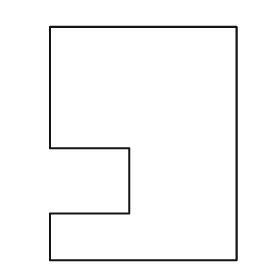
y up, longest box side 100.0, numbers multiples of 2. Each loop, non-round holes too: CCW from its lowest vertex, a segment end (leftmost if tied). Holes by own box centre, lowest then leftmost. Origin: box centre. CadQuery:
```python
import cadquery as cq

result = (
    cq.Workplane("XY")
    .moveTo(-40.0, -50.0)
    .lineTo(40.0, -50.0)
    .lineTo(40.0, 50.0)
    .lineTo(-40.0, 50.0)
    .lineTo(-40.0, -2.0)
    .lineTo(-6.0, -2.0)
    .lineTo(-6.0, -30.0)
    .lineTo(-40.0, -30.0)
    .close()
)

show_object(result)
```